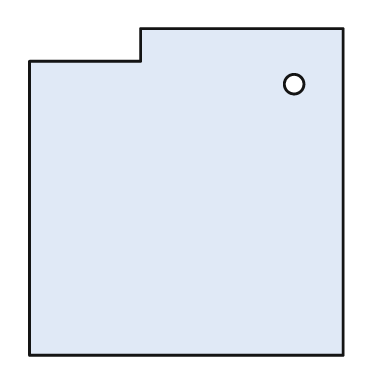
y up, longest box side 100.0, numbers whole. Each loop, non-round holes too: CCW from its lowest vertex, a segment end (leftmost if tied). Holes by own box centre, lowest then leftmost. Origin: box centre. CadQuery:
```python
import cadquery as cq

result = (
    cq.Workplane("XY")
    .moveTo(-48.0, -50.0)
    .lineTo(48.0, -50.0)
    .lineTo(48.0, 50.0)
    .lineTo(-14.0, 50.0)
    .lineTo(-14.0, 40.0)
    .lineTo(-48.0, 40.0)
    .close()
    .moveTo(33.0, 33.0)
    .circle(3.0)
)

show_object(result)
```